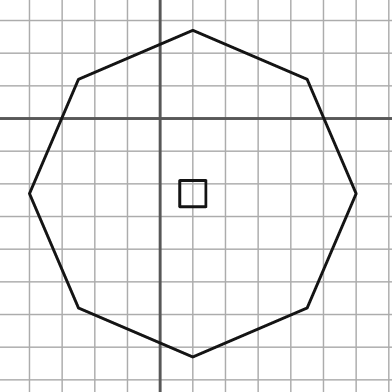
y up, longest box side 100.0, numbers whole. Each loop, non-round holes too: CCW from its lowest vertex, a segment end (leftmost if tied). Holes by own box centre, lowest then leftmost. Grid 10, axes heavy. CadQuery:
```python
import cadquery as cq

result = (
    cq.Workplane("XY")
    .moveTo(10.0, -73.0)
    .lineTo(45.0, -58.0)
    .lineTo(60.0, -23.0)
    .lineTo(45.0, 12.0)
    .lineTo(10.0, 27.0)
    .lineTo(-25.0, 12.0)
    .lineTo(-40.0, -23.0)
    .lineTo(-25.0, -58.0)
    .close()
    .moveTo(6.0, -27.0)
    .lineTo(14.0, -27.0)
    .lineTo(14.0, -19.0)
    .lineTo(6.0, -19.0)
    .close()
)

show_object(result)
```